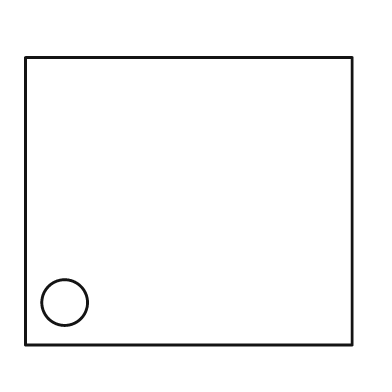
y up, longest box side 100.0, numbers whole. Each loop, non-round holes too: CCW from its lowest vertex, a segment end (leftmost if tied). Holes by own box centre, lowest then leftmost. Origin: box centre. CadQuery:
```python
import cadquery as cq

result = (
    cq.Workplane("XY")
    .moveTo(-50.0, -44.0)
    .lineTo(50.0, -44.0)
    .lineTo(50.0, 44.0)
    .lineTo(-50.0, 44.0)
    .close()
    .moveTo(-38.0, -31.0)
    .circle(7.0)
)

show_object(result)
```